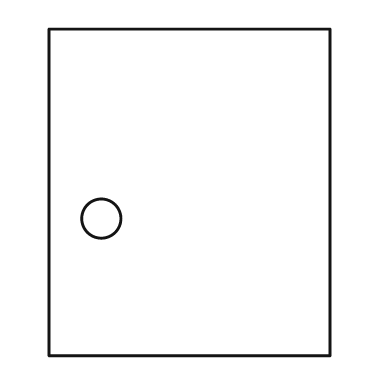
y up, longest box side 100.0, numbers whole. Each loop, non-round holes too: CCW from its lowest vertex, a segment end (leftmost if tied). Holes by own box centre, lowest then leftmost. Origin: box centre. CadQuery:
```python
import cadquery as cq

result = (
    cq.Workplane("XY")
    .moveTo(-43.0, -50.0)
    .lineTo(43.0, -50.0)
    .lineTo(43.0, 50.0)
    .lineTo(-43.0, 50.0)
    .close()
    .moveTo(-27.0, -8.0)
    .circle(6.0)
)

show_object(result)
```